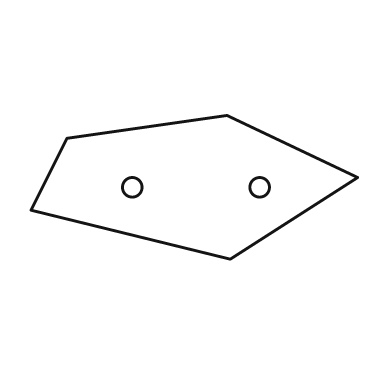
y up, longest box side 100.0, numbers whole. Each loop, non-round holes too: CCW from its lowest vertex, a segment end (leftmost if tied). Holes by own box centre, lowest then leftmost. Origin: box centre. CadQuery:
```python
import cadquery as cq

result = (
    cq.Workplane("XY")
    .moveTo(11.0, -22.0)
    .lineTo(50.0, 3.0)
    .lineTo(10.0, 22.0)
    .lineTo(-39.0, 15.0)
    .lineTo(-50.0, -7.0)
    .close()
    .moveTo(-19.0, 0.0)
    .circle(3.0)
    .moveTo(20.0, 0.0)
    .circle(3.0)
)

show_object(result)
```